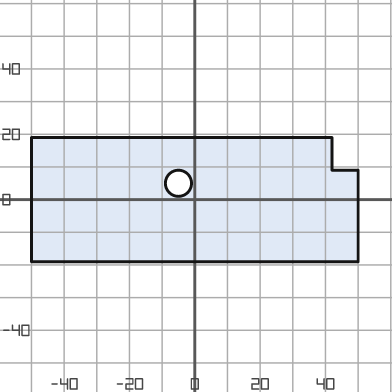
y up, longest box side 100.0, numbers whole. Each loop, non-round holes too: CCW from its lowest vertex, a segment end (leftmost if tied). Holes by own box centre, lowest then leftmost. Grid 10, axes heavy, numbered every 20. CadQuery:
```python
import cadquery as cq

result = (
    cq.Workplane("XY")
    .moveTo(-50.0, -19.0)
    .lineTo(50.0, -19.0)
    .lineTo(50.0, 9.0)
    .lineTo(42.0, 9.0)
    .lineTo(42.0, 19.0)
    .lineTo(-50.0, 19.0)
    .close()
    .moveTo(-5.0, 5.0)
    .circle(4.0)
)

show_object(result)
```